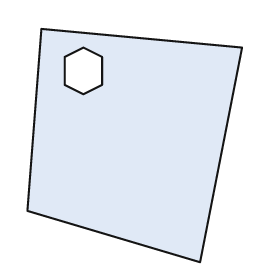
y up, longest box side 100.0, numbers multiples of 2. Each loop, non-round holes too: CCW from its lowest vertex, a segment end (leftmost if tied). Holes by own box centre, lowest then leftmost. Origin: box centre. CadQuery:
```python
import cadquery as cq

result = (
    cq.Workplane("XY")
    .moveTo(28.0, -50.0)
    .lineTo(46.0, 42.0)
    .lineTo(-40.0, 50.0)
    .lineTo(-46.0, -28.0)
    .close()
    .moveTo(-22.0, 22.0)
    .lineTo(-14.0, 26.0)
    .lineTo(-14.0, 38.0)
    .lineTo(-22.0, 42.0)
    .lineTo(-30.0, 38.0)
    .lineTo(-30.0, 26.0)
    .close()
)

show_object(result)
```